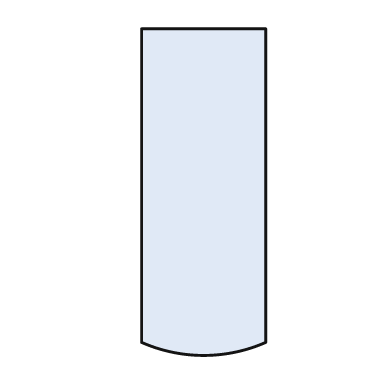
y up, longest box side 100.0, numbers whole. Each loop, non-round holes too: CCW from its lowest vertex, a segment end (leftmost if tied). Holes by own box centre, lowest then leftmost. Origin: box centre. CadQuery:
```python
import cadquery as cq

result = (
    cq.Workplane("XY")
    .moveTo(-19.0, -46.0)
    .threePointArc((0.0, -50.0), (19.0, -46.0))
    .lineTo(19.0, 50.0)
    .lineTo(-19.0, 50.0)
    .close()
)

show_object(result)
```